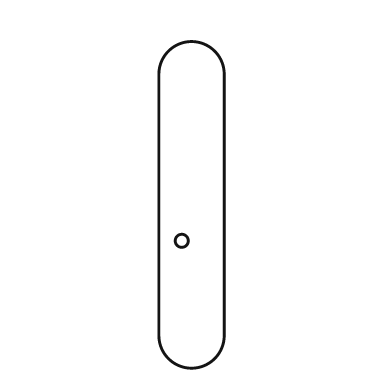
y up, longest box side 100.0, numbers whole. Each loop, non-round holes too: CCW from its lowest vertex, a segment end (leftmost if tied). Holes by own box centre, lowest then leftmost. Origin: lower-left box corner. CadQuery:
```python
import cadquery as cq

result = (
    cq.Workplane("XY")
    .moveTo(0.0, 10.0)
    .threePointArc((10.0, 0.0), (20.0, 10.0))
    .lineTo(20.0, 90.0)
    .threePointArc((10.0, 100.0), (0.0, 90.0))
    .close()
    .moveTo(7.0, 39.0)
    .circle(2.0)
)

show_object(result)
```